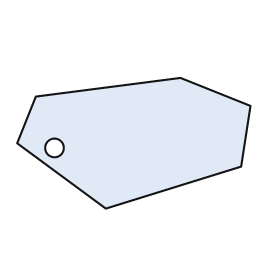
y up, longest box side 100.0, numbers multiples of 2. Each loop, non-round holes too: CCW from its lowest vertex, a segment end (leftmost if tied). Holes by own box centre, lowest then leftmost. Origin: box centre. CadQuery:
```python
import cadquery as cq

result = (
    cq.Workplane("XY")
    .moveTo(-12.0, -28.0)
    .lineTo(46.0, -10.0)
    .lineTo(50.0, 16.0)
    .lineTo(20.0, 28.0)
    .lineTo(-42.0, 20.0)
    .lineTo(-50.0, 0.0)
    .close()
    .moveTo(-34.0, -2.0)
    .circle(4.0)
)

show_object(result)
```